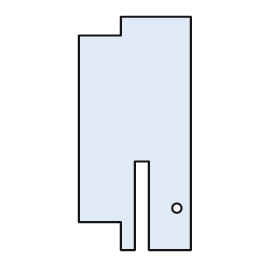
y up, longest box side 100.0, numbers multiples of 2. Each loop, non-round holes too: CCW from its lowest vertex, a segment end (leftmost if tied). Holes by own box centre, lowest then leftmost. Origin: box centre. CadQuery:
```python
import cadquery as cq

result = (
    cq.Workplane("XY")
    .moveTo(-6.0, -50.0)
    .lineTo(0.0, -50.0)
    .lineTo(0.0, -12.0)
    .lineTo(6.0, -12.0)
    .lineTo(6.0, -50.0)
    .lineTo(24.0, -50.0)
    .lineTo(24.0, 50.0)
    .lineTo(-6.0, 50.0)
    .lineTo(-6.0, 42.0)
    .lineTo(-24.0, 42.0)
    .lineTo(-24.0, -38.0)
    .lineTo(-6.0, -38.0)
    .close()
    .moveTo(18.0, -32.0)
    .circle(2.0)
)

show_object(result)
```